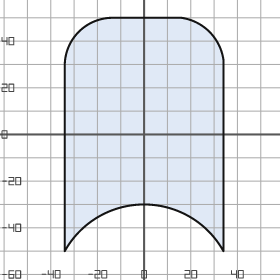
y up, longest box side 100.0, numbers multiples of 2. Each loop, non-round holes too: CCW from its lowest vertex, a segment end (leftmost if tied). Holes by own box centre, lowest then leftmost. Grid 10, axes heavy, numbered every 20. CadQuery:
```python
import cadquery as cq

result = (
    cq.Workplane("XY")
    .moveTo(-34.0, -50.0)
    .threePointArc((0.0, -30.0), (34.0, -50.0))
    .lineTo(34.0, 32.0)
    .threePointArc((28.0, 44.0), (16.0, 50.0))
    .lineTo(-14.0, 50.0)
    .threePointArc((-28.0, 44.0), (-34.0, 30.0))
    .close()
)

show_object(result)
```